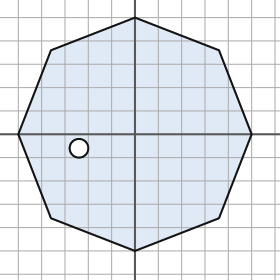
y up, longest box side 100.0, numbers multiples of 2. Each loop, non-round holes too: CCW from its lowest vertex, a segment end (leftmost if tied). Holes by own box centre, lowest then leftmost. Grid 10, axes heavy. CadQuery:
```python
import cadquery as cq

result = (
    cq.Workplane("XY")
    .moveTo(0.0, -50.0)
    .lineTo(36.0, -36.0)
    .lineTo(50.0, 0.0)
    .lineTo(36.0, 36.0)
    .lineTo(0.0, 50.0)
    .lineTo(-36.0, 36.0)
    .lineTo(-50.0, 0.0)
    .lineTo(-36.0, -36.0)
    .close()
    .moveTo(-24.0, -6.0)
    .circle(4.0)
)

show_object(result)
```